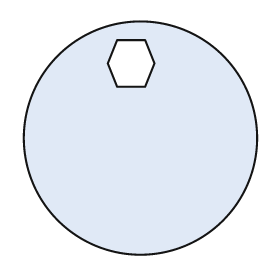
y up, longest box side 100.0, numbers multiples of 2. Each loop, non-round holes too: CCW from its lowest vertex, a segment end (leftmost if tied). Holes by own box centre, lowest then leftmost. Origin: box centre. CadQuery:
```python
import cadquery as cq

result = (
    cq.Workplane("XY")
    .moveTo(0.0, 0.0)
    .circle(50.0)
    .moveTo(-10.0, 22.0)
    .lineTo(2.0, 22.0)
    .lineTo(6.0, 32.0)
    .lineTo(2.0, 42.0)
    .lineTo(-10.0, 42.0)
    .lineTo(-14.0, 32.0)
    .close()
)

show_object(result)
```